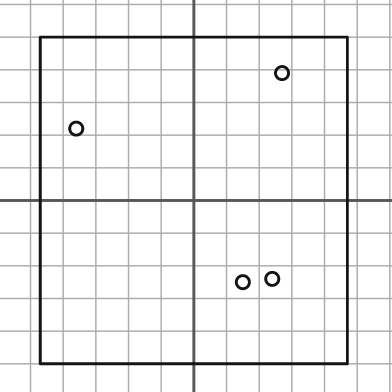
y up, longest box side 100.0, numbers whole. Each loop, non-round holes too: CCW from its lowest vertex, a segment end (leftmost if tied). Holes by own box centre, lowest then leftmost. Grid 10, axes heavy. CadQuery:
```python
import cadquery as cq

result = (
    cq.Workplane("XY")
    .moveTo(-47.0, -50.0)
    .lineTo(47.0, -50.0)
    .lineTo(47.0, 50.0)
    .lineTo(-47.0, 50.0)
    .close()
    .moveTo(15.0, -25.0)
    .circle(2.0)
    .moveTo(24.0, -24.0)
    .circle(2.0)
    .moveTo(-36.0, 22.0)
    .circle(2.0)
    .moveTo(27.0, 39.0)
    .circle(2.0)
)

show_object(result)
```